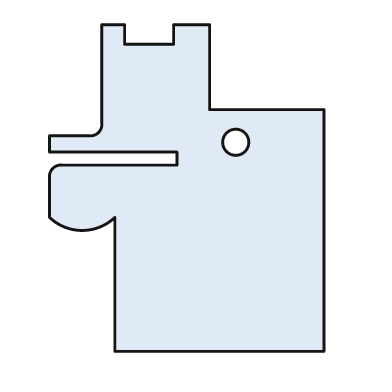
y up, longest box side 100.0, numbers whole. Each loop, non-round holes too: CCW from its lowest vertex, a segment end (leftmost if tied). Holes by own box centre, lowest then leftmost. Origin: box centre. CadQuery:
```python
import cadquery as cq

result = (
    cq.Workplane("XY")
    .moveTo(-22.0, -50.0)
    .lineTo(42.0, -50.0)
    .lineTo(42.0, 24.0)
    .lineTo(7.0, 24.0)
    .lineTo(7.0, 50.0)
    .lineTo(-4.0, 50.0)
    .lineTo(-4.0, 44.0)
    .lineTo(-19.0, 44.0)
    .lineTo(-19.0, 50.0)
    .lineTo(-26.0, 50.0)
    .lineTo(-26.0, 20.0)
    .threePointArc((-27.0, 17.0), (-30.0, 16.0))
    .lineTo(-42.0, 16.0)
    .lineTo(-42.0, 11.0)
    .lineTo(-3.0, 11.0)
    .lineTo(-3.0, 7.0)
    .lineTo(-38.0, 7.0)
    .threePointArc((-41.0, 6.0), (-42.0, 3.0))
    .lineTo(-42.0, -9.0)
    .threePointArc((-32.0, -13.0), (-22.0, -9.0))
    .close()
    .moveTo(15.0, 14.0)
    .circle(4.0)
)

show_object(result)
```